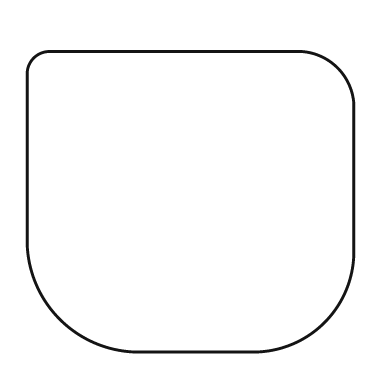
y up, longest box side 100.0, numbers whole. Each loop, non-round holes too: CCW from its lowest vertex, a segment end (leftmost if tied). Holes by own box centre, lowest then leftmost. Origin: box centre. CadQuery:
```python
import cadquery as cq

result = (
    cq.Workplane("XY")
    .moveTo(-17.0, -46.0)
    .lineTo(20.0, -46.0)
    .threePointArc((41.0, -37.0), (50.0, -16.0))
    .lineTo(50.0, 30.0)
    .threePointArc((45.0, 41.0), (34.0, 46.0))
    .lineTo(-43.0, 46.0)
    .threePointArc((-48.0, 44.0), (-50.0, 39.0))
    .lineTo(-50.0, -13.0)
    .threePointArc((-40.0, -36.0), (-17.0, -46.0))
    .close()
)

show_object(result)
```